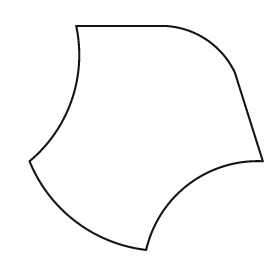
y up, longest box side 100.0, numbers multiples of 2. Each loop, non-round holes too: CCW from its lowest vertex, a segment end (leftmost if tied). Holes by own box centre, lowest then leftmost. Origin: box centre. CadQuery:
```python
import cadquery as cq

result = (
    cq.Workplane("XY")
    .moveTo(0.0, -48.0)
    .threePointArc((18.0, -20.0), (50.0, -10.0))
    .lineTo(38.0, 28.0)
    .threePointArc((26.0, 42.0), (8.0, 48.0))
    .lineTo(-30.0, 48.0)
    .threePointArc((-32.0, 16.0), (-50.0, -10.0))
    .threePointArc((-30.0, -36.0), (0.0, -48.0))
    .close()
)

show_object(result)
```